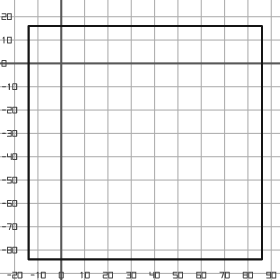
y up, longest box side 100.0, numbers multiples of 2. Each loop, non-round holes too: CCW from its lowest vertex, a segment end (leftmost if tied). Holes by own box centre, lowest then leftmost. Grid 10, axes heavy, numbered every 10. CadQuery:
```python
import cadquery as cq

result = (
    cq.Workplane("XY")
    .moveTo(-14.0, -84.0)
    .lineTo(86.0, -84.0)
    .lineTo(86.0, 16.0)
    .lineTo(-14.0, 16.0)
    .close()
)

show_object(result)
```